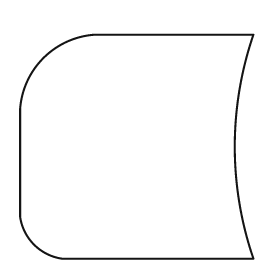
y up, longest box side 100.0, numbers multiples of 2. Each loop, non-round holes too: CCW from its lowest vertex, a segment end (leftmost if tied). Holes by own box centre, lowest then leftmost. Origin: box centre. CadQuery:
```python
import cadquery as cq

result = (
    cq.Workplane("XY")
    .moveTo(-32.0, -48.0)
    .lineTo(50.0, -48.0)
    .threePointArc((42.0, 0.0), (50.0, 48.0))
    .lineTo(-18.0, 48.0)
    .threePointArc((-40.0, 38.0), (-50.0, 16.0))
    .lineTo(-50.0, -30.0)
    .threePointArc((-44.0, -42.0), (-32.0, -48.0))
    .close()
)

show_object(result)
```